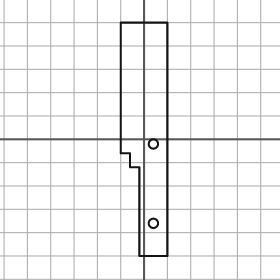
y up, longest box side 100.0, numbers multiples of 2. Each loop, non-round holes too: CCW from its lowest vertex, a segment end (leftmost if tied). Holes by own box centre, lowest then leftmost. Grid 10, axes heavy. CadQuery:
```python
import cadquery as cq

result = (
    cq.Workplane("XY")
    .moveTo(-2.0, -50.0)
    .lineTo(10.0, -50.0)
    .lineTo(10.0, 50.0)
    .lineTo(-10.0, 50.0)
    .lineTo(-10.0, -6.0)
    .lineTo(-6.0, -6.0)
    .lineTo(-6.0, -12.0)
    .lineTo(-2.0, -12.0)
    .close()
    .moveTo(4.0, -36.0)
    .circle(2.0)
    .moveTo(4.0, -2.0)
    .circle(2.0)
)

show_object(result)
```